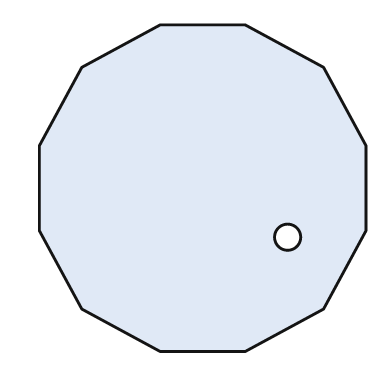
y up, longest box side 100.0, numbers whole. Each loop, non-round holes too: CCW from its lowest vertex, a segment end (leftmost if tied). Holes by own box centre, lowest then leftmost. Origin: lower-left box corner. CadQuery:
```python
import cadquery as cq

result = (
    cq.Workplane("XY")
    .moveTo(37.0, 0.0)
    .lineTo(63.0, 0.0)
    .lineTo(87.0, 13.0)
    .lineTo(100.0, 37.0)
    .lineTo(100.0, 63.0)
    .lineTo(87.0, 87.0)
    .lineTo(63.0, 100.0)
    .lineTo(37.0, 100.0)
    .lineTo(13.0, 87.0)
    .lineTo(0.0, 63.0)
    .lineTo(0.0, 37.0)
    .lineTo(13.0, 13.0)
    .close()
    .moveTo(76.0, 35.0)
    .circle(4.0)
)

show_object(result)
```